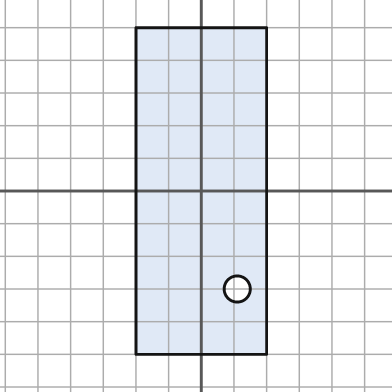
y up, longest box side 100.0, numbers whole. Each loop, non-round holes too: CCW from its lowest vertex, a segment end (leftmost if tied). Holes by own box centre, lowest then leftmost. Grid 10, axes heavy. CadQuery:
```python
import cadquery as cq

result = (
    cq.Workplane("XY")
    .moveTo(-20.0, -50.0)
    .lineTo(20.0, -50.0)
    .lineTo(20.0, 50.0)
    .lineTo(-20.0, 50.0)
    .close()
    .moveTo(11.0, -30.0)
    .circle(4.0)
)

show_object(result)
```